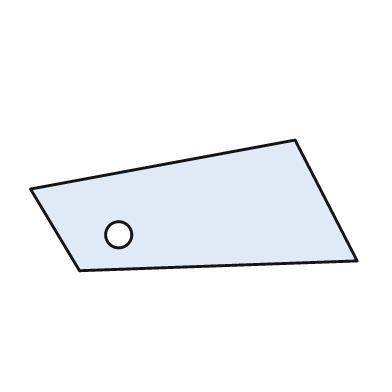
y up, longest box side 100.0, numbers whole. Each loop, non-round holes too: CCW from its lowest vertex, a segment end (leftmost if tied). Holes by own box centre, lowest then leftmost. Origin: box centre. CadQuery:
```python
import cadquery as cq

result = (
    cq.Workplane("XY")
    .moveTo(-35.0, -20.0)
    .lineTo(50.0, -17.0)
    .lineTo(31.0, 20.0)
    .lineTo(-50.0, 5.0)
    .close()
    .moveTo(-23.0, -9.0)
    .circle(4.0)
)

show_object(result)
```